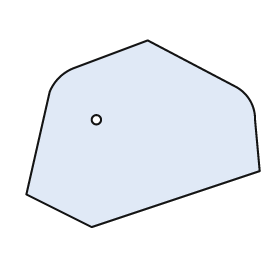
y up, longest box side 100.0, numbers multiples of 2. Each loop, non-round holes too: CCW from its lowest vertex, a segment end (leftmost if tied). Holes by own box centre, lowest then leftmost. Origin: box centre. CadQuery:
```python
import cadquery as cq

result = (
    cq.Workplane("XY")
    .moveTo(-22.0, -40.0)
    .lineTo(50.0, -16.0)
    .lineTo(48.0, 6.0)
    .threePointArc((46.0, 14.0), (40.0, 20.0))
    .lineTo(2.0, 40.0)
    .lineTo(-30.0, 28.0)
    .threePointArc((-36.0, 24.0), (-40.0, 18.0))
    .lineTo(-50.0, -26.0)
    .close()
    .moveTo(-20.0, 6.0)
    .circle(2.0)
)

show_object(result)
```